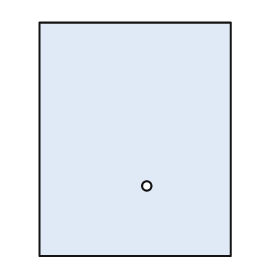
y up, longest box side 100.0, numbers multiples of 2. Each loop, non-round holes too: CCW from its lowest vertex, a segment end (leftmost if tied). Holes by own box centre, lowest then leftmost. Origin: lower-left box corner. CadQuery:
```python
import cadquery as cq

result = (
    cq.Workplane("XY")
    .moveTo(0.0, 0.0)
    .lineTo(82.0, 0.0)
    .lineTo(82.0, 100.0)
    .lineTo(0.0, 100.0)
    .close()
    .moveTo(46.0, 30.0)
    .circle(2.0)
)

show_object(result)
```